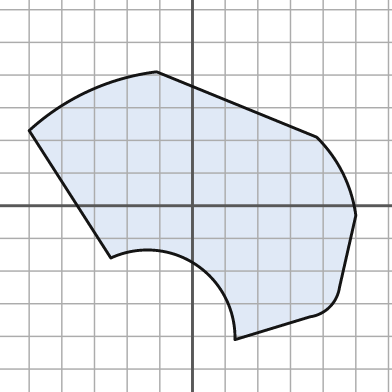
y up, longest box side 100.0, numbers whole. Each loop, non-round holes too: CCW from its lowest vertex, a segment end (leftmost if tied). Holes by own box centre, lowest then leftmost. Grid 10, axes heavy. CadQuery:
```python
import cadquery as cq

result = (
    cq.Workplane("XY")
    .moveTo(13.0, -41.0)
    .lineTo(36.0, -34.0)
    .threePointArc((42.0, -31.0), (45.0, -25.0))
    .lineTo(50.0, -3.0)
    .threePointArc((46.0, 10.0), (38.0, 21.0))
    .lineTo(-11.0, 41.0)
    .threePointArc((-32.0, 35.0), (-50.0, 23.0))
    .lineTo(-25.0, -16.0)
    .threePointArc((1.0, -18.0), (13.0, -41.0))
    .close()
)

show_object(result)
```